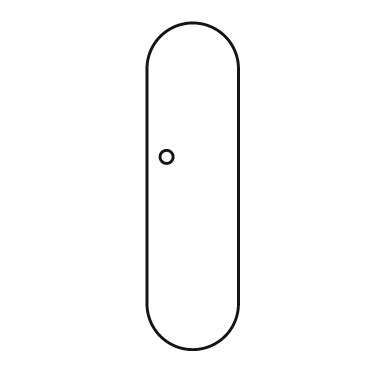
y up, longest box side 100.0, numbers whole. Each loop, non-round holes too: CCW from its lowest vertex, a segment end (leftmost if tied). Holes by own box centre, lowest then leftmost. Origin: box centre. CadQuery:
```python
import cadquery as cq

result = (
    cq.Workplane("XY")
    .moveTo(-14.0, -36.0)
    .threePointArc((0.0, -50.0), (14.0, -36.0))
    .lineTo(14.0, 36.0)
    .threePointArc((0.0, 50.0), (-14.0, 36.0))
    .close()
    .moveTo(-8.0, 9.0)
    .circle(2.0)
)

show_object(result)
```